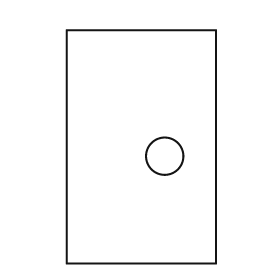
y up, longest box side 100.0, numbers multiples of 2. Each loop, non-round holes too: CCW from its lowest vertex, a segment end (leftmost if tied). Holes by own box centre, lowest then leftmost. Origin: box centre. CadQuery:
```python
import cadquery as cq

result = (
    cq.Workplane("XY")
    .moveTo(-32.0, -50.0)
    .lineTo(32.0, -50.0)
    .lineTo(32.0, 50.0)
    .lineTo(-32.0, 50.0)
    .close()
    .moveTo(10.0, -4.0)
    .circle(8.0)
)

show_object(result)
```